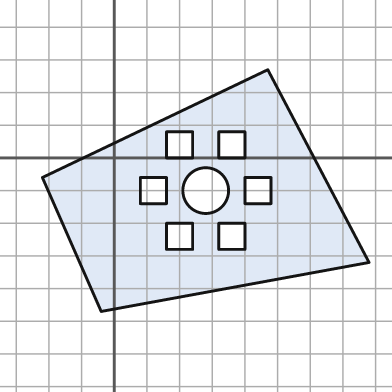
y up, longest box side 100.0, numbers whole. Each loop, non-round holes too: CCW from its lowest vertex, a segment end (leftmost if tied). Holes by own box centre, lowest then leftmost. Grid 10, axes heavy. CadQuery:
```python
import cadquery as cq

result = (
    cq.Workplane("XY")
    .moveTo(-4.0, -47.0)
    .lineTo(78.0, -32.0)
    .lineTo(47.0, 27.0)
    .lineTo(-22.0, -6.0)
    .close()
    .moveTo(16.0, -28.0)
    .lineTo(24.0, -28.0)
    .lineTo(24.0, -20.0)
    .lineTo(16.0, -20.0)
    .close()
    .moveTo(32.0, -28.0)
    .lineTo(40.0, -28.0)
    .lineTo(40.0, -20.0)
    .lineTo(32.0, -20.0)
    .close()
    .moveTo(8.0, -14.0)
    .lineTo(16.0, -14.0)
    .lineTo(16.0, -6.0)
    .lineTo(8.0, -6.0)
    .close()
    .moveTo(28.0, -10.0)
    .circle(7.0)
    .moveTo(40.0, -14.0)
    .lineTo(48.0, -14.0)
    .lineTo(48.0, -6.0)
    .lineTo(40.0, -6.0)
    .close()
    .moveTo(16.0, 0.0)
    .lineTo(24.0, 0.0)
    .lineTo(24.0, 8.0)
    .lineTo(16.0, 8.0)
    .close()
    .moveTo(32.0, 0.0)
    .lineTo(40.0, 0.0)
    .lineTo(40.0, 8.0)
    .lineTo(32.0, 8.0)
    .close()
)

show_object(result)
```